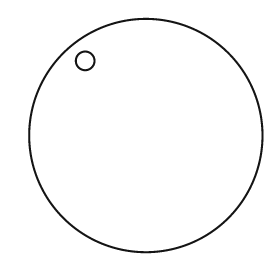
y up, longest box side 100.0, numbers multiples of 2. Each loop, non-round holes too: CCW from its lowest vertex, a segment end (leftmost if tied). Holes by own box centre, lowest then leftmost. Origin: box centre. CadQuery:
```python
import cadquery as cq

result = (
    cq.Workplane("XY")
    .moveTo(0.0, 0.0)
    .circle(50.0)
    .moveTo(-26.0, 32.0)
    .circle(4.0)
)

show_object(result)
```